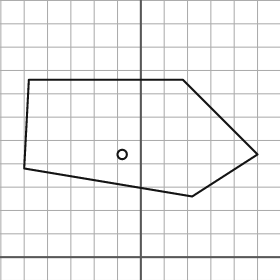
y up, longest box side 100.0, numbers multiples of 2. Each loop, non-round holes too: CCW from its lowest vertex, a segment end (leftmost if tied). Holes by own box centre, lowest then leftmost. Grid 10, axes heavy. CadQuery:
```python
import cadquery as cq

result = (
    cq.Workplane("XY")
    .moveTo(22.0, 26.0)
    .lineTo(50.0, 44.0)
    .lineTo(18.0, 76.0)
    .lineTo(-48.0, 76.0)
    .lineTo(-50.0, 38.0)
    .close()
    .moveTo(-8.0, 44.0)
    .circle(2.0)
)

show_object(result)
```